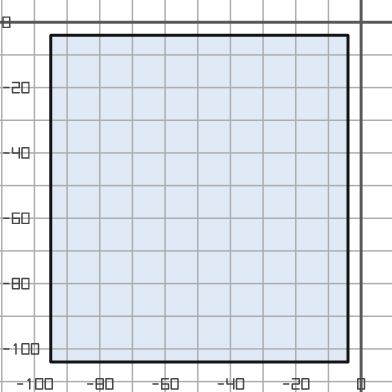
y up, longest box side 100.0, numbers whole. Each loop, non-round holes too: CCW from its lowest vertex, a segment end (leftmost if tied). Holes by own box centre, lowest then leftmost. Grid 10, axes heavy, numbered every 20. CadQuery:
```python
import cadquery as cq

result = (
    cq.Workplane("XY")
    .moveTo(-95.0, -104.0)
    .lineTo(-4.0, -104.0)
    .lineTo(-4.0, -4.0)
    .lineTo(-95.0, -4.0)
    .close()
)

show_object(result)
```